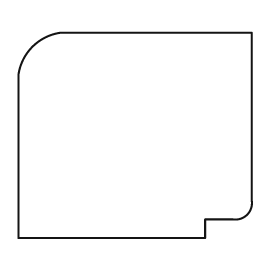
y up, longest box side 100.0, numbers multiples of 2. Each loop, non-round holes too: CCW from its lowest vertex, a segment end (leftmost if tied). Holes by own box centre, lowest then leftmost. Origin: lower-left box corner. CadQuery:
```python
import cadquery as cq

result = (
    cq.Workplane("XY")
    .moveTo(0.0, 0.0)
    .lineTo(80.0, 0.0)
    .lineTo(80.0, 8.0)
    .lineTo(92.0, 8.0)
    .threePointArc((98.0, 10.0), (100.0, 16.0))
    .lineTo(100.0, 88.0)
    .lineTo(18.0, 88.0)
    .threePointArc((6.0, 82.0), (0.0, 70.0))
    .close()
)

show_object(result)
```